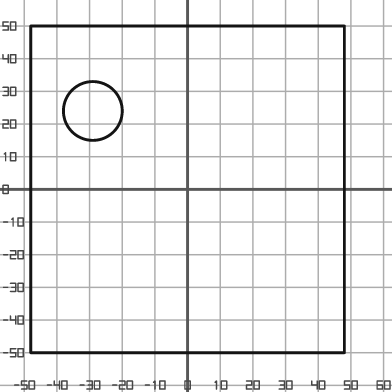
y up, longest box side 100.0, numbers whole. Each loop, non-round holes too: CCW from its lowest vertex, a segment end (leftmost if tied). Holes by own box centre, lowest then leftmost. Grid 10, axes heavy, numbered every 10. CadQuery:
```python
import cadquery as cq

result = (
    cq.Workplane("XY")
    .moveTo(-48.0, -50.0)
    .lineTo(48.0, -50.0)
    .lineTo(48.0, 50.0)
    .lineTo(-48.0, 50.0)
    .close()
    .moveTo(-29.0, 24.0)
    .circle(9.0)
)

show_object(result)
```